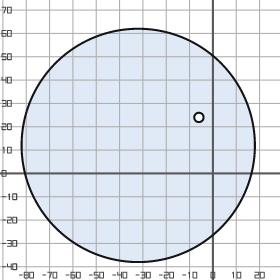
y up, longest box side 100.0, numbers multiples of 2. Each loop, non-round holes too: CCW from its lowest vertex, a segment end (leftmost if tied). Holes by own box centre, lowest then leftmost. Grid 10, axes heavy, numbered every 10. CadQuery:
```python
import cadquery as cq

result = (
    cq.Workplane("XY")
    .moveTo(-32.0, 12.0)
    .circle(50.0)
    .moveTo(-6.0, 24.0)
    .circle(2.0)
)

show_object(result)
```